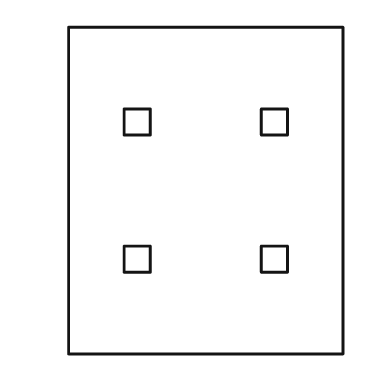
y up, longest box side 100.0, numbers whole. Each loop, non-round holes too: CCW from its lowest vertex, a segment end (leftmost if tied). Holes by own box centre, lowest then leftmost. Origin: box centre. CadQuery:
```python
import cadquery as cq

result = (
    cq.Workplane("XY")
    .moveTo(-42.0, -50.0)
    .lineTo(42.0, -50.0)
    .lineTo(42.0, 50.0)
    .lineTo(-42.0, 50.0)
    .close()
    .moveTo(-25.0, -25.0)
    .lineTo(-17.0, -25.0)
    .lineTo(-17.0, -17.0)
    .lineTo(-25.0, -17.0)
    .close()
    .moveTo(17.0, -25.0)
    .lineTo(25.0, -25.0)
    .lineTo(25.0, -17.0)
    .lineTo(17.0, -17.0)
    .close()
    .moveTo(-25.0, 17.0)
    .lineTo(-17.0, 17.0)
    .lineTo(-17.0, 25.0)
    .lineTo(-25.0, 25.0)
    .close()
    .moveTo(17.0, 17.0)
    .lineTo(25.0, 17.0)
    .lineTo(25.0, 25.0)
    .lineTo(17.0, 25.0)
    .close()
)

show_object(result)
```